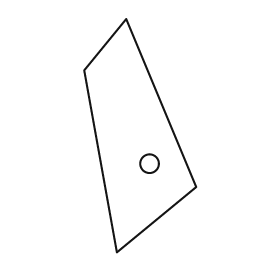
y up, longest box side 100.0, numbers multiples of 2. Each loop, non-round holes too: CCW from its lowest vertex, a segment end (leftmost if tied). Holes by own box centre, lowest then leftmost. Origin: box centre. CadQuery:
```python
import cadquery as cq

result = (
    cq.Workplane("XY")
    .moveTo(-10.0, -50.0)
    .lineTo(24.0, -22.0)
    .lineTo(-6.0, 50.0)
    .lineTo(-24.0, 28.0)
    .close()
    .moveTo(4.0, -12.0)
    .circle(4.0)
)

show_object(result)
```